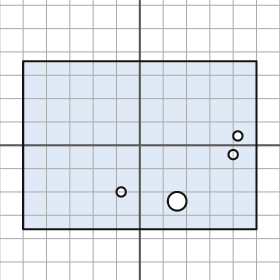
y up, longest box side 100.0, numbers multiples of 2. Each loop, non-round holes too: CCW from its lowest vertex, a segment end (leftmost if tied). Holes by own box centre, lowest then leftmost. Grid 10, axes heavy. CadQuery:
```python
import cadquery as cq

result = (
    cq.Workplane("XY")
    .moveTo(-50.0, -36.0)
    .lineTo(50.0, -36.0)
    .lineTo(50.0, 36.0)
    .lineTo(-50.0, 36.0)
    .close()
    .moveTo(16.0, -24.0)
    .circle(4.0)
    .moveTo(-8.0, -20.0)
    .circle(2.0)
    .moveTo(40.0, -4.0)
    .circle(2.0)
    .moveTo(42.0, 4.0)
    .circle(2.0)
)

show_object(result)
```